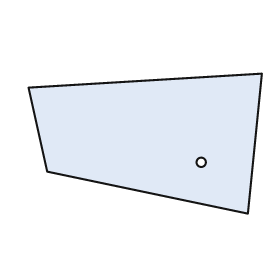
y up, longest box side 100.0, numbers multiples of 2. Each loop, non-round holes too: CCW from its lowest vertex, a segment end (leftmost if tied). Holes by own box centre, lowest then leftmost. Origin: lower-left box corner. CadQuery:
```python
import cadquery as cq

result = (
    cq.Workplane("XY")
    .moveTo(94.0, 0.0)
    .lineTo(100.0, 60.0)
    .lineTo(0.0, 54.0)
    .lineTo(8.0, 18.0)
    .close()
    .moveTo(74.0, 22.0)
    .circle(2.0)
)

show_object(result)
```